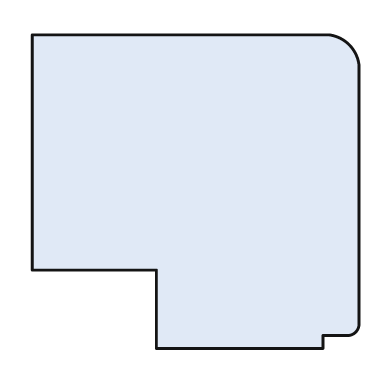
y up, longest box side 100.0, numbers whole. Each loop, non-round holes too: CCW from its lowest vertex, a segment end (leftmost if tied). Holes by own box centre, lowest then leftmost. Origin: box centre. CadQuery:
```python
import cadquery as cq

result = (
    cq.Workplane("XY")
    .moveTo(-12.0, -48.0)
    .lineTo(39.0, -48.0)
    .lineTo(39.0, -44.0)
    .lineTo(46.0, -44.0)
    .threePointArc((49.0, -43.0), (50.0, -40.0))
    .lineTo(50.0, 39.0)
    .threePointArc((47.0, 45.0), (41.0, 48.0))
    .lineTo(-50.0, 48.0)
    .lineTo(-50.0, -24.0)
    .lineTo(-12.0, -24.0)
    .close()
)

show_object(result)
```